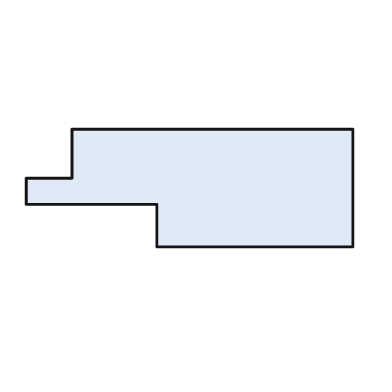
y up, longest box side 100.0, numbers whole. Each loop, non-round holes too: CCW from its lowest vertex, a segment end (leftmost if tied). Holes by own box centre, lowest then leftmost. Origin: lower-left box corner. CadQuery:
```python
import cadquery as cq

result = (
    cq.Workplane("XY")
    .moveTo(40.0, 0.0)
    .lineTo(100.0, 0.0)
    .lineTo(100.0, 36.0)
    .lineTo(14.0, 36.0)
    .lineTo(14.0, 21.0)
    .lineTo(0.0, 21.0)
    .lineTo(0.0, 13.0)
    .lineTo(40.0, 13.0)
    .close()
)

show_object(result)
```